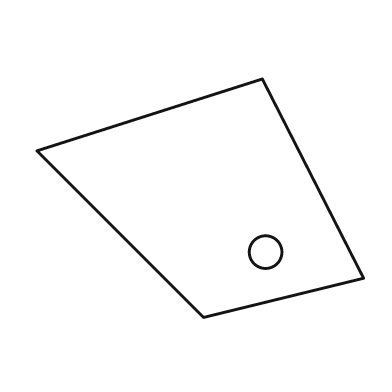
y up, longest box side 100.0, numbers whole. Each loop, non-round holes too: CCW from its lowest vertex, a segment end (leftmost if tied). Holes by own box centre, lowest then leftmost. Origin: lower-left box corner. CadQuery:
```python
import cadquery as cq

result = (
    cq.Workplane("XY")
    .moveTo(51.0, 0.0)
    .lineTo(100.0, 12.0)
    .lineTo(69.0, 73.0)
    .lineTo(0.0, 51.0)
    .close()
    .moveTo(70.0, 20.0)
    .circle(5.0)
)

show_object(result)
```